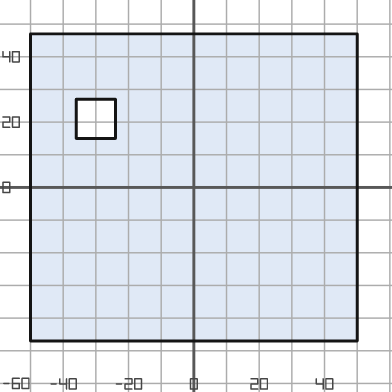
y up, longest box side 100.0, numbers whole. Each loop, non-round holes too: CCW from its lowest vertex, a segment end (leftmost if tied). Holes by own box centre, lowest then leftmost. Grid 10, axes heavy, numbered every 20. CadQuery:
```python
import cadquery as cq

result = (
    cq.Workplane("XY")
    .moveTo(-50.0, -47.0)
    .lineTo(50.0, -47.0)
    .lineTo(50.0, 47.0)
    .lineTo(-50.0, 47.0)
    .close()
    .moveTo(-36.0, 15.0)
    .lineTo(-24.0, 15.0)
    .lineTo(-24.0, 27.0)
    .lineTo(-36.0, 27.0)
    .close()
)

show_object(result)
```